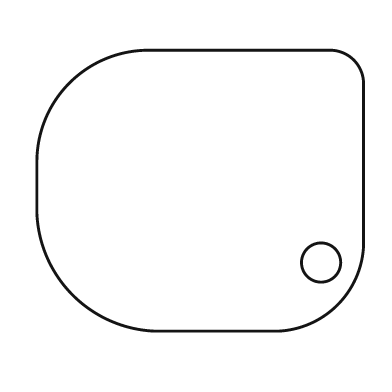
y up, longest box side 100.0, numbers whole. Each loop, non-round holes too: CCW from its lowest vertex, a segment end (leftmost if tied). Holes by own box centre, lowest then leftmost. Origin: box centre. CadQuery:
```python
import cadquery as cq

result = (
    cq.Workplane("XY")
    .moveTo(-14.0, -43.0)
    .lineTo(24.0, -43.0)
    .threePointArc((42.0, -35.0), (50.0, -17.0))
    .lineTo(50.0, 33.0)
    .threePointArc((47.0, 40.0), (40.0, 43.0))
    .lineTo(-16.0, 43.0)
    .threePointArc((-40.0, 33.0), (-50.0, 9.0))
    .lineTo(-50.0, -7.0)
    .threePointArc((-39.0, -32.0), (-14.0, -43.0))
    .close()
    .moveTo(37.0, -22.0)
    .circle(6.0)
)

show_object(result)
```